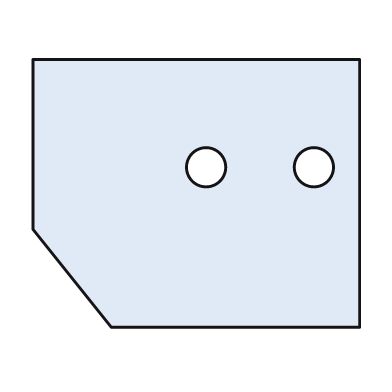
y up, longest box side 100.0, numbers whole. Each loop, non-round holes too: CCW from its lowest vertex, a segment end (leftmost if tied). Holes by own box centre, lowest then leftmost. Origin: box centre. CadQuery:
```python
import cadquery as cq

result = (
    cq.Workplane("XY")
    .moveTo(-26.0, -41.0)
    .lineTo(50.0, -41.0)
    .lineTo(50.0, 41.0)
    .lineTo(-50.0, 41.0)
    .lineTo(-50.0, -11.0)
    .close()
    .moveTo(3.0, 8.0)
    .circle(6.0)
    .moveTo(36.0, 8.0)
    .circle(6.0)
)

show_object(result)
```